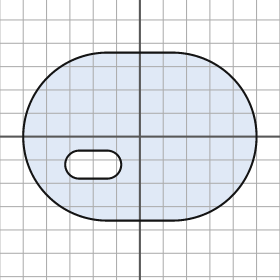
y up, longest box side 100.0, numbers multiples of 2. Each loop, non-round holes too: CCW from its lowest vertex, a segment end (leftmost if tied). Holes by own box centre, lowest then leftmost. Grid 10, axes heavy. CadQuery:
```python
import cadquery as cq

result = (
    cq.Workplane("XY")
    .moveTo(-14.0, -36.0)
    .lineTo(14.0, -36.0)
    .threePointArc((50.0, 0.0), (14.0, 36.0))
    .lineTo(-14.0, 36.0)
    .threePointArc((-50.0, 0.0), (-14.0, -36.0))
    .close()
    .moveTo(-26.0, -18.0)
    .lineTo(-14.0, -18.0)
    .threePointArc((-8.0, -12.0), (-14.0, -6.0))
    .lineTo(-26.0, -6.0)
    .threePointArc((-32.0, -12.0), (-26.0, -18.0))
    .close()
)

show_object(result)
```